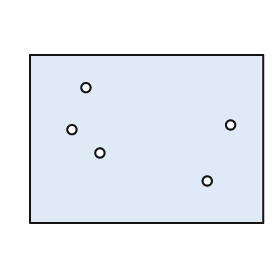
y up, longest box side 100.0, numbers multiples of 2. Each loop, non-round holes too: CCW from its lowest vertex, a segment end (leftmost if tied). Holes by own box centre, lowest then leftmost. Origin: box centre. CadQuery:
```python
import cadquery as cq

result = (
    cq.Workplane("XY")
    .moveTo(-50.0, -36.0)
    .lineTo(50.0, -36.0)
    .lineTo(50.0, 36.0)
    .lineTo(-50.0, 36.0)
    .close()
    .moveTo(26.0, -18.0)
    .circle(2.0)
    .moveTo(-20.0, -6.0)
    .circle(2.0)
    .moveTo(-32.0, 4.0)
    .circle(2.0)
    .moveTo(36.0, 6.0)
    .circle(2.0)
    .moveTo(-26.0, 22.0)
    .circle(2.0)
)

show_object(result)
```